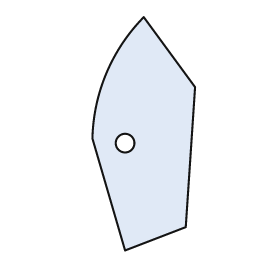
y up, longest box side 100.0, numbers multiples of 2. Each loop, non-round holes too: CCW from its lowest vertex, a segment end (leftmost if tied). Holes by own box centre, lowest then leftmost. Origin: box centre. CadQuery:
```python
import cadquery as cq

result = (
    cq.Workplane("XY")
    .moveTo(-8.0, -50.0)
    .lineTo(18.0, -40.0)
    .lineTo(22.0, 20.0)
    .lineTo(0.0, 50.0)
    .threePointArc((-16.0, 26.0), (-22.0, -2.0))
    .close()
    .moveTo(-8.0, -4.0)
    .circle(4.0)
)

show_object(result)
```